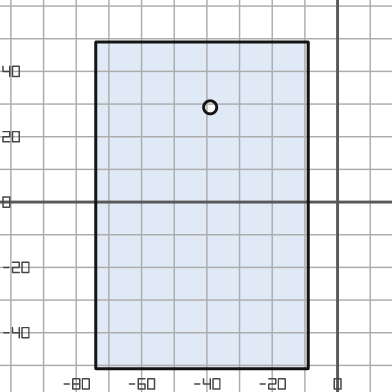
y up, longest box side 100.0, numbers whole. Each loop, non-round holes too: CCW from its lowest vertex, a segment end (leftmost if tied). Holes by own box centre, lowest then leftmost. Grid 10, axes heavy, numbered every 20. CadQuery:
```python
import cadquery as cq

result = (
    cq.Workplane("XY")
    .moveTo(-74.0, -51.0)
    .lineTo(-9.0, -51.0)
    .lineTo(-9.0, 49.0)
    .lineTo(-74.0, 49.0)
    .close()
    .moveTo(-39.0, 29.0)
    .circle(2.0)
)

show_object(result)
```